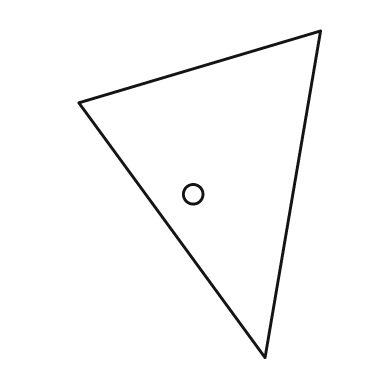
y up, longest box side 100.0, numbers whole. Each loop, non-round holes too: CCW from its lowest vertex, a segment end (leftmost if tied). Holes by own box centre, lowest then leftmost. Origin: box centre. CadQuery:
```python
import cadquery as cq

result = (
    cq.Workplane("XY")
    .moveTo(20.0, -50.0)
    .lineTo(37.0, 50.0)
    .lineTo(-37.0, 28.0)
    .close()
    .moveTo(-2.0, 0.0)
    .circle(3.0)
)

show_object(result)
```